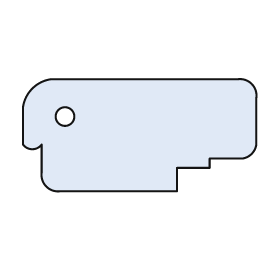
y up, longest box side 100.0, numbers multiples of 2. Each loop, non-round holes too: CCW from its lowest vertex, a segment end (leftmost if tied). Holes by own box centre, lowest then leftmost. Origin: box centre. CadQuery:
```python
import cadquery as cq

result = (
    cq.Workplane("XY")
    .moveTo(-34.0, -24.0)
    .lineTo(16.0, -24.0)
    .lineTo(16.0, -14.0)
    .lineTo(30.0, -14.0)
    .lineTo(30.0, -10.0)
    .lineTo(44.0, -10.0)
    .threePointArc((48.0, -8.0), (50.0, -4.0))
    .lineTo(50.0, 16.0)
    .threePointArc((48.0, 22.0), (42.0, 24.0))
    .lineTo(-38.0, 24.0)
    .threePointArc((-46.0, 20.0), (-50.0, 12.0))
    .lineTo(-50.0, -4.0)
    .threePointArc((-46.0, -6.0), (-42.0, -4.0))
    .lineTo(-42.0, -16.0)
    .threePointArc((-40.0, -22.0), (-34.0, -24.0))
    .close()
    .moveTo(-32.0, 8.0)
    .circle(4.0)
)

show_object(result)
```